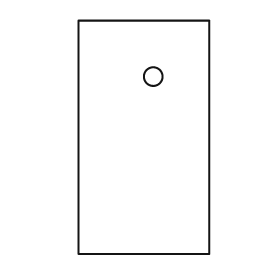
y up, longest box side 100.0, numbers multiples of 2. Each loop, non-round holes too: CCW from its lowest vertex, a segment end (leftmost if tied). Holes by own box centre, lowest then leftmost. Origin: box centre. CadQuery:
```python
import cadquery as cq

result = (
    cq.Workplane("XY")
    .moveTo(-28.0, -50.0)
    .lineTo(28.0, -50.0)
    .lineTo(28.0, 50.0)
    .lineTo(-28.0, 50.0)
    .close()
    .moveTo(4.0, 26.0)
    .circle(4.0)
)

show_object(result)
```